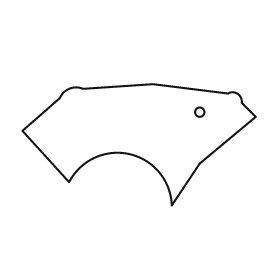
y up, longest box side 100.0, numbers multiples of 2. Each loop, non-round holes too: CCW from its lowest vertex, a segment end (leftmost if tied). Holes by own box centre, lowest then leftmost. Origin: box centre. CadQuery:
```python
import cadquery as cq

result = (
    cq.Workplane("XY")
    .moveTo(14.0, -26.0)
    .lineTo(26.0, -8.0)
    .lineTo(50.0, 12.0)
    .lineTo(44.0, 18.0)
    .threePointArc((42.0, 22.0), (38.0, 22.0))
    .lineTo(6.0, 26.0)
    .lineTo(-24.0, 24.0)
    .threePointArc((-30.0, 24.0), (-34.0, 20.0))
    .lineTo(-50.0, 6.0)
    .lineTo(-30.0, -16.0)
    .threePointArc((-4.0, -4.0), (14.0, -26.0))
    .close()
    .moveTo(26.0, 14.0)
    .circle(2.0)
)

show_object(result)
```